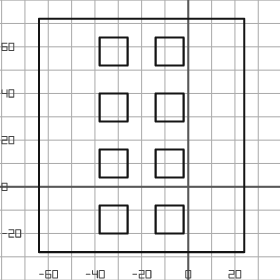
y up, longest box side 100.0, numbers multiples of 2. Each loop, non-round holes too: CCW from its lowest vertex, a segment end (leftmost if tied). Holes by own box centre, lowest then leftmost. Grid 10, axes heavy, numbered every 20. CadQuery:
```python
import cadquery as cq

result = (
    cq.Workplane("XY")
    .moveTo(-64.0, -28.0)
    .lineTo(24.0, -28.0)
    .lineTo(24.0, 72.0)
    .lineTo(-64.0, 72.0)
    .close()
    .moveTo(-38.0, -20.0)
    .lineTo(-26.0, -20.0)
    .lineTo(-26.0, -8.0)
    .lineTo(-38.0, -8.0)
    .close()
    .moveTo(-14.0, -20.0)
    .lineTo(-2.0, -20.0)
    .lineTo(-2.0, -8.0)
    .lineTo(-14.0, -8.0)
    .close()
    .moveTo(-38.0, 4.0)
    .lineTo(-26.0, 4.0)
    .lineTo(-26.0, 16.0)
    .lineTo(-38.0, 16.0)
    .close()
    .moveTo(-14.0, 4.0)
    .lineTo(-2.0, 4.0)
    .lineTo(-2.0, 16.0)
    .lineTo(-14.0, 16.0)
    .close()
    .moveTo(-38.0, 28.0)
    .lineTo(-26.0, 28.0)
    .lineTo(-26.0, 40.0)
    .lineTo(-38.0, 40.0)
    .close()
    .moveTo(-14.0, 28.0)
    .lineTo(-2.0, 28.0)
    .lineTo(-2.0, 40.0)
    .lineTo(-14.0, 40.0)
    .close()
    .moveTo(-38.0, 52.0)
    .lineTo(-26.0, 52.0)
    .lineTo(-26.0, 64.0)
    .lineTo(-38.0, 64.0)
    .close()
    .moveTo(-14.0, 52.0)
    .lineTo(-2.0, 52.0)
    .lineTo(-2.0, 64.0)
    .lineTo(-14.0, 64.0)
    .close()
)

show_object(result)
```